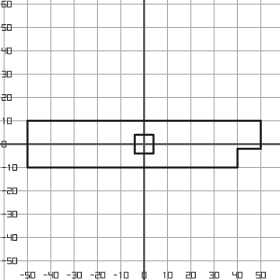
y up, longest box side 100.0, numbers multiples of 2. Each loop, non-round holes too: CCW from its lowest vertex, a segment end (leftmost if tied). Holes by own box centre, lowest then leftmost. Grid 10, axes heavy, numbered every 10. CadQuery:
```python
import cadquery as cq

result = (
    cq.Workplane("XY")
    .moveTo(-50.0, -10.0)
    .lineTo(40.0, -10.0)
    .lineTo(40.0, -2.0)
    .lineTo(50.0, -2.0)
    .lineTo(50.0, 10.0)
    .lineTo(-50.0, 10.0)
    .close()
    .moveTo(-4.0, -4.0)
    .lineTo(4.0, -4.0)
    .lineTo(4.0, 4.0)
    .lineTo(-4.0, 4.0)
    .close()
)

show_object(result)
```